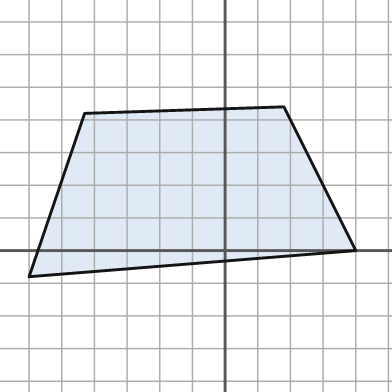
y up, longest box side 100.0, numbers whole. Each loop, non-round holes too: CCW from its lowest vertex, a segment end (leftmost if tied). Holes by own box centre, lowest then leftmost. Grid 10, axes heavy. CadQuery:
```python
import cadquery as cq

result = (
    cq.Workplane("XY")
    .moveTo(-60.0, -8.0)
    .lineTo(40.0, 0.0)
    .lineTo(18.0, 44.0)
    .lineTo(-43.0, 42.0)
    .close()
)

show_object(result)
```